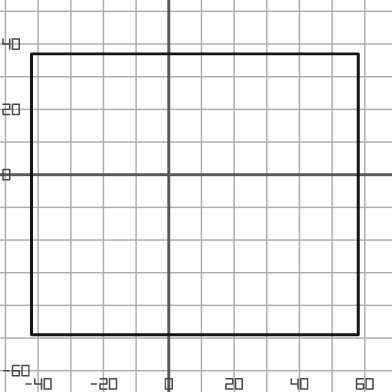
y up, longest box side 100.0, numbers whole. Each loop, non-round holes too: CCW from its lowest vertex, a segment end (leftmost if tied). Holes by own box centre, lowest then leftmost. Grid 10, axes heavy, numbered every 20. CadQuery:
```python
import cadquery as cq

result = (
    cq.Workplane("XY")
    .moveTo(-42.0, -49.0)
    .lineTo(58.0, -49.0)
    .lineTo(58.0, 37.0)
    .lineTo(-42.0, 37.0)
    .close()
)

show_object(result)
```